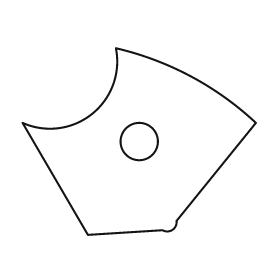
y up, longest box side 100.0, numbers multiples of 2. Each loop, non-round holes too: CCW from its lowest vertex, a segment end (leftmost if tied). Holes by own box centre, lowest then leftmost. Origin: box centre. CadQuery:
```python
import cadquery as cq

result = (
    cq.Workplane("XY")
    .moveTo(-22.0, -40.0)
    .lineTo(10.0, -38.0)
    .threePointArc((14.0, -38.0), (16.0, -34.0))
    .lineTo(50.0, 8.0)
    .threePointArc((22.0, 28.0), (-10.0, 40.0))
    .threePointArc((-20.0, 12.0), (-50.0, 8.0))
    .close()
    .moveTo(0.0, 0.0)
    .circle(8.0)
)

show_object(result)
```